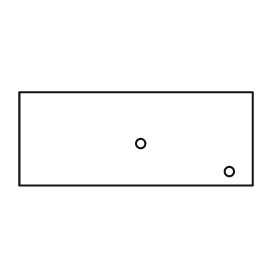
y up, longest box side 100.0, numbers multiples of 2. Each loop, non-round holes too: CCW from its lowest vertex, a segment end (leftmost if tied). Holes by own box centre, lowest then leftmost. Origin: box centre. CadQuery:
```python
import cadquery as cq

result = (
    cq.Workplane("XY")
    .moveTo(-50.0, -20.0)
    .lineTo(50.0, -20.0)
    .lineTo(50.0, 20.0)
    .lineTo(-50.0, 20.0)
    .close()
    .moveTo(40.0, -14.0)
    .circle(2.0)
    .moveTo(2.0, -2.0)
    .circle(2.0)
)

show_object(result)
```